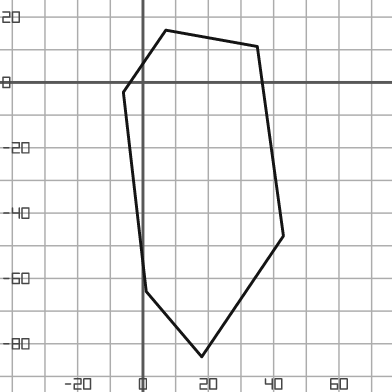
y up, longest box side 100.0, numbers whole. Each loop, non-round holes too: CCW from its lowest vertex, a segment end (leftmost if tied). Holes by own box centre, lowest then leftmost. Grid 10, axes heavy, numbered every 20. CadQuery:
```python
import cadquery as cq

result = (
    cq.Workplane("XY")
    .moveTo(18.0, -84.0)
    .lineTo(43.0, -47.0)
    .lineTo(35.0, 11.0)
    .lineTo(7.0, 16.0)
    .lineTo(-6.0, -3.0)
    .lineTo(1.0, -64.0)
    .close()
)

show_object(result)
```